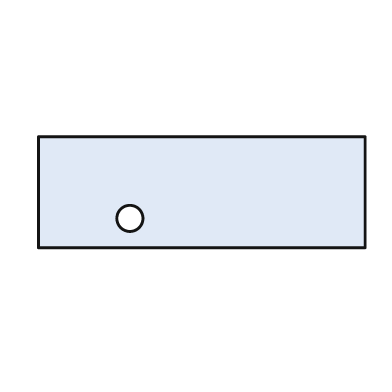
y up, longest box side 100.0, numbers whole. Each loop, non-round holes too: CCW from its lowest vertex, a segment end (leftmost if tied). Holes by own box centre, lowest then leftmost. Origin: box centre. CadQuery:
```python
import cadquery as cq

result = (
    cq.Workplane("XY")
    .moveTo(-50.0, -17.0)
    .lineTo(50.0, -17.0)
    .lineTo(50.0, 17.0)
    .lineTo(-50.0, 17.0)
    .close()
    .moveTo(-22.0, -8.0)
    .circle(4.0)
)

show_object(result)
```